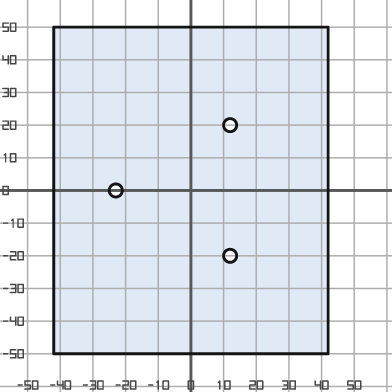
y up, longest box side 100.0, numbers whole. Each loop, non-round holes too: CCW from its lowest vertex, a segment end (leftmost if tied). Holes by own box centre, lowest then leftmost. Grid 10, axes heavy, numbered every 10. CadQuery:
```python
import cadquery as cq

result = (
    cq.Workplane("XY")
    .moveTo(-42.0, -50.0)
    .lineTo(42.0, -50.0)
    .lineTo(42.0, 50.0)
    .lineTo(-42.0, 50.0)
    .close()
    .moveTo(12.0, -20.0)
    .circle(2.0)
    .moveTo(-23.0, 0.0)
    .circle(2.0)
    .moveTo(12.0, 20.0)
    .circle(2.0)
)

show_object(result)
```